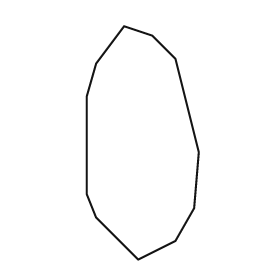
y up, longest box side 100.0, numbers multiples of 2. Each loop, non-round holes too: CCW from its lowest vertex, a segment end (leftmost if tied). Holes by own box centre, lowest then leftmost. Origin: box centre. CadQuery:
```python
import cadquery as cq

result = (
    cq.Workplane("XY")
    .moveTo(-2.0, -50.0)
    .lineTo(14.0, -42.0)
    .lineTo(22.0, -28.0)
    .lineTo(24.0, -4.0)
    .lineTo(14.0, 36.0)
    .lineTo(4.0, 46.0)
    .lineTo(-8.0, 50.0)
    .lineTo(-20.0, 34.0)
    .lineTo(-24.0, 20.0)
    .lineTo(-24.0, -22.0)
    .lineTo(-20.0, -32.0)
    .close()
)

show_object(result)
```